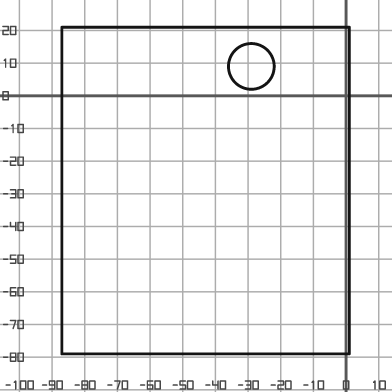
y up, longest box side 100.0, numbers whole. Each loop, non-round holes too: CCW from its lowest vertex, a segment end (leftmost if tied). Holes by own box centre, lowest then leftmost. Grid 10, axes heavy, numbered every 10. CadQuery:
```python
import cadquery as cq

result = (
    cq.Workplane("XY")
    .moveTo(-87.0, -79.0)
    .lineTo(1.0, -79.0)
    .lineTo(1.0, 21.0)
    .lineTo(-87.0, 21.0)
    .close()
    .moveTo(-29.0, 9.0)
    .circle(7.0)
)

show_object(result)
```